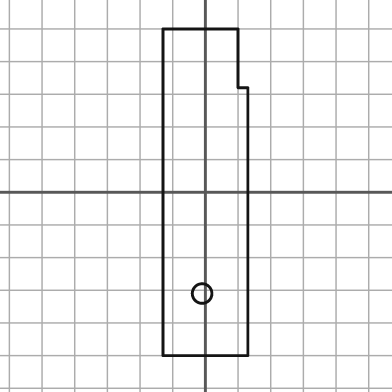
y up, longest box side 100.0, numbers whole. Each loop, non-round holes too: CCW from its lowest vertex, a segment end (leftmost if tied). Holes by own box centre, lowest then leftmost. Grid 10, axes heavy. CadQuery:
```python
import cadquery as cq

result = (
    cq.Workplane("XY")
    .moveTo(-13.0, -50.0)
    .lineTo(13.0, -50.0)
    .lineTo(13.0, 32.0)
    .lineTo(10.0, 32.0)
    .lineTo(10.0, 50.0)
    .lineTo(-13.0, 50.0)
    .close()
    .moveTo(-1.0, -31.0)
    .circle(3.0)
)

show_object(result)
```